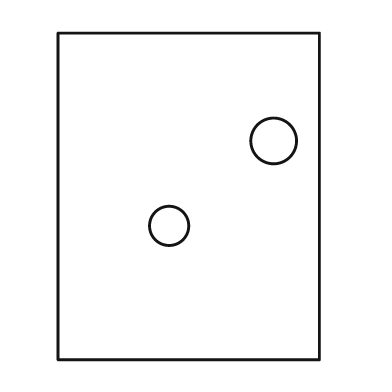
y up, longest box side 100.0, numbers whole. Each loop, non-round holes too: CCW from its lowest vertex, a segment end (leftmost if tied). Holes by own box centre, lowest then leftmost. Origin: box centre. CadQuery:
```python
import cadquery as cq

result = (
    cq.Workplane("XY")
    .moveTo(-40.0, -50.0)
    .lineTo(40.0, -50.0)
    .lineTo(40.0, 50.0)
    .lineTo(-40.0, 50.0)
    .close()
    .moveTo(-6.0, -9.0)
    .circle(6.0)
    .moveTo(26.0, 17.0)
    .circle(7.0)
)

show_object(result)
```